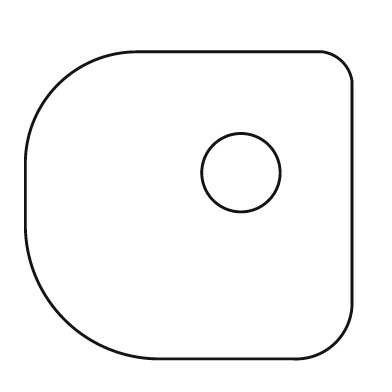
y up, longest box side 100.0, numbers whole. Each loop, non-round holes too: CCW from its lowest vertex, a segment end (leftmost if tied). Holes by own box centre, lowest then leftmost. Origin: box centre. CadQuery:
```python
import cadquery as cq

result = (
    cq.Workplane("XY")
    .moveTo(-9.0, -47.0)
    .lineTo(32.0, -47.0)
    .threePointArc((45.0, -42.0), (50.0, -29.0))
    .lineTo(50.0, 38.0)
    .threePointArc((47.0, 44.0), (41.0, 47.0))
    .lineTo(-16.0, 47.0)
    .threePointArc((-40.0, 37.0), (-50.0, 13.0))
    .lineTo(-50.0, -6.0)
    .threePointArc((-38.0, -35.0), (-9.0, -47.0))
    .close()
    .moveTo(16.0, 10.0)
    .circle(12.0)
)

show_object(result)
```